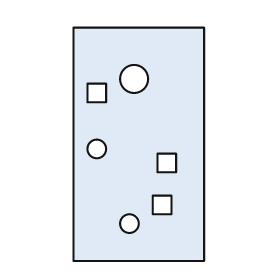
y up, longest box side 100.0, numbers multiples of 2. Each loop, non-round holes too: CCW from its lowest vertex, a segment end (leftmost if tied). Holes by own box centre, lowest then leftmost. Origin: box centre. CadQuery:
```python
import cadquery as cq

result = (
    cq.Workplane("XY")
    .moveTo(-28.0, -50.0)
    .lineTo(28.0, -50.0)
    .lineTo(28.0, 50.0)
    .lineTo(-28.0, 50.0)
    .close()
    .moveTo(-4.0, -34.0)
    .circle(4.0)
    .moveTo(6.0, -30.0)
    .lineTo(14.0, -30.0)
    .lineTo(14.0, -22.0)
    .lineTo(6.0, -22.0)
    .close()
    .moveTo(8.0, -12.0)
    .lineTo(16.0, -12.0)
    .lineTo(16.0, -4.0)
    .lineTo(8.0, -4.0)
    .close()
    .moveTo(-18.0, -2.0)
    .circle(4.0)
    .moveTo(-22.0, 18.0)
    .lineTo(-14.0, 18.0)
    .lineTo(-14.0, 26.0)
    .lineTo(-22.0, 26.0)
    .close()
    .moveTo(-2.0, 28.0)
    .circle(6.0)
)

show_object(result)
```